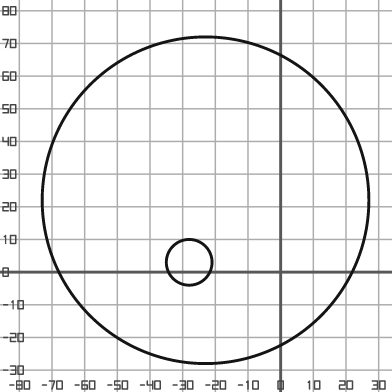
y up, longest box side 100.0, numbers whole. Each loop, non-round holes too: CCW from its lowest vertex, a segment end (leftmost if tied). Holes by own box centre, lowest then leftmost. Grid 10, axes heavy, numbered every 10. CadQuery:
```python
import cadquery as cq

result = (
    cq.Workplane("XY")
    .moveTo(-23.0, 22.0)
    .circle(50.0)
    .moveTo(-28.0, 3.0)
    .circle(7.0)
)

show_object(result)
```